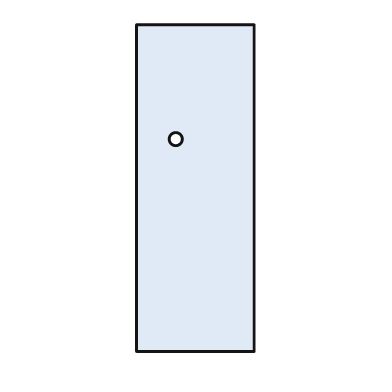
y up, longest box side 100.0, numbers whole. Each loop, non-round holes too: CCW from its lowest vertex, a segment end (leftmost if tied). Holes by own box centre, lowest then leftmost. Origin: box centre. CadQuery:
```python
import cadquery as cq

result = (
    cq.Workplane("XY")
    .moveTo(-18.0, -50.0)
    .lineTo(18.0, -50.0)
    .lineTo(18.0, 50.0)
    .lineTo(-18.0, 50.0)
    .close()
    .moveTo(-6.0, 15.0)
    .circle(2.0)
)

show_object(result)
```